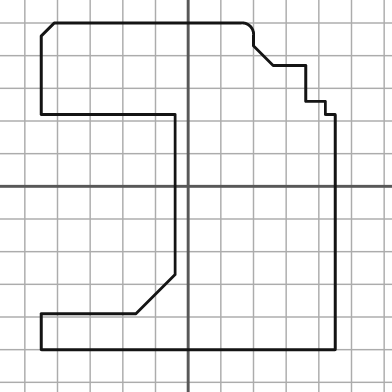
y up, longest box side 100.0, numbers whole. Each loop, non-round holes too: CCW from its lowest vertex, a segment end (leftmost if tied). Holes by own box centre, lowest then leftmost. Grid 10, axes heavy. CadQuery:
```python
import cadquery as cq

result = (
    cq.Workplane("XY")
    .moveTo(-45.0, -50.0)
    .lineTo(45.0, -50.0)
    .lineTo(45.0, 22.0)
    .lineTo(42.0, 22.0)
    .lineTo(42.0, 26.0)
    .lineTo(36.0, 26.0)
    .lineTo(36.0, 37.0)
    .lineTo(26.0, 37.0)
    .lineTo(20.0, 43.0)
    .lineTo(20.0, 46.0)
    .threePointArc((19.0, 49.0), (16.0, 50.0))
    .lineTo(-41.0, 50.0)
    .lineTo(-45.0, 46.0)
    .lineTo(-45.0, 22.0)
    .lineTo(-4.0, 22.0)
    .lineTo(-4.0, -27.0)
    .lineTo(-16.0, -39.0)
    .lineTo(-45.0, -39.0)
    .close()
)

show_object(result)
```